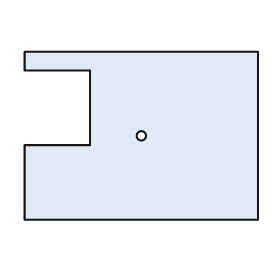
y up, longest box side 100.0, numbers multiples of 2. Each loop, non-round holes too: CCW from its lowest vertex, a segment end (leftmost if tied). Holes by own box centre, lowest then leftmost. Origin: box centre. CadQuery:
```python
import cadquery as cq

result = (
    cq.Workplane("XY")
    .moveTo(-50.0, -36.0)
    .lineTo(50.0, -36.0)
    .lineTo(50.0, 36.0)
    .lineTo(-50.0, 36.0)
    .lineTo(-50.0, 28.0)
    .lineTo(-22.0, 28.0)
    .lineTo(-22.0, -4.0)
    .lineTo(-50.0, -4.0)
    .close()
    .moveTo(0.0, 0.0)
    .circle(2.0)
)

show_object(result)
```